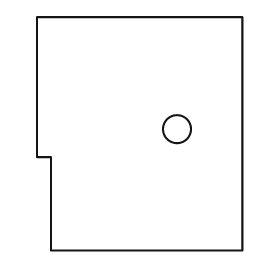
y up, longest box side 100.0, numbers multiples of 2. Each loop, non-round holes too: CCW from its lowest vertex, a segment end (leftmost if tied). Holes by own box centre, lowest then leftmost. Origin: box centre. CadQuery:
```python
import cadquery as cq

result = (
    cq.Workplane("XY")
    .moveTo(-38.0, -50.0)
    .lineTo(44.0, -50.0)
    .lineTo(44.0, 50.0)
    .lineTo(-44.0, 50.0)
    .lineTo(-44.0, -10.0)
    .lineTo(-38.0, -10.0)
    .close()
    .moveTo(16.0, 2.0)
    .circle(6.0)
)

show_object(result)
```